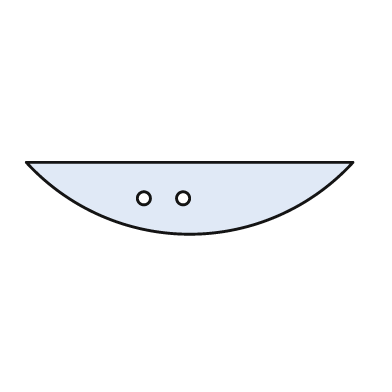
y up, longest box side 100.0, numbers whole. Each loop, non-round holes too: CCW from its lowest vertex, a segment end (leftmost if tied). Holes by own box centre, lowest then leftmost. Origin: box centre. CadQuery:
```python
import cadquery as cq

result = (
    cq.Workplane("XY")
    .moveTo(-50.0, 11.0)
    .threePointArc((0.0, -11.0), (50.0, 11.0))
    .close()
    .moveTo(-14.0, 0.0)
    .circle(2.0)
    .moveTo(-2.0, 0.0)
    .circle(2.0)
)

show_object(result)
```